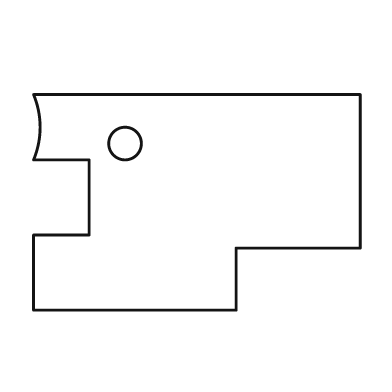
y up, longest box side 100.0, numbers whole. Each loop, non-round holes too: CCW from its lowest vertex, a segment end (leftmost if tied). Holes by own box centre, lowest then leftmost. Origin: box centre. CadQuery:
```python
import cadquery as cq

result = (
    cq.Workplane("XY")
    .moveTo(-50.0, -33.0)
    .lineTo(12.0, -33.0)
    .lineTo(12.0, -14.0)
    .lineTo(50.0, -14.0)
    .lineTo(50.0, 33.0)
    .lineTo(-50.0, 33.0)
    .threePointArc((-48.0, 23.0), (-50.0, 13.0))
    .lineTo(-33.0, 13.0)
    .lineTo(-33.0, -10.0)
    .lineTo(-50.0, -10.0)
    .close()
    .moveTo(-22.0, 18.0)
    .circle(5.0)
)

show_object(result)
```